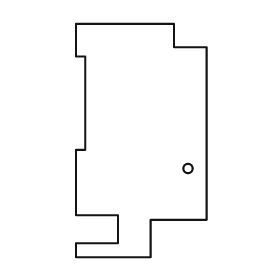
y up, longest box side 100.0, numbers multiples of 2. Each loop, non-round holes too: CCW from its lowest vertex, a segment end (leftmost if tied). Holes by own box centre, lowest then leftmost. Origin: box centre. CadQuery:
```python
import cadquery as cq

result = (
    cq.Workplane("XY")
    .moveTo(-28.0, -50.0)
    .lineTo(4.0, -50.0)
    .lineTo(4.0, -34.0)
    .lineTo(28.0, -34.0)
    .lineTo(28.0, 40.0)
    .lineTo(14.0, 40.0)
    .lineTo(14.0, 50.0)
    .lineTo(-28.0, 50.0)
    .lineTo(-28.0, 36.0)
    .lineTo(-24.0, 36.0)
    .lineTo(-24.0, -4.0)
    .lineTo(-28.0, -4.0)
    .lineTo(-28.0, -32.0)
    .lineTo(-10.0, -32.0)
    .lineTo(-10.0, -44.0)
    .lineTo(-28.0, -44.0)
    .close()
    .moveTo(20.0, -12.0)
    .circle(2.0)
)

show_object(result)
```